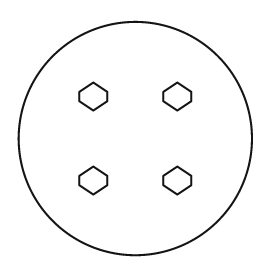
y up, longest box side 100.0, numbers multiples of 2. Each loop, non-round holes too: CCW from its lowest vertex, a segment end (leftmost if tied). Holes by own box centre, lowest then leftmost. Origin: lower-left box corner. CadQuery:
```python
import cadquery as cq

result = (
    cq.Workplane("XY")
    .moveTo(50.0, 50.0)
    .circle(50.0)
    .moveTo(32.0, 26.0)
    .lineTo(38.0, 30.0)
    .lineTo(38.0, 34.0)
    .lineTo(32.0, 38.0)
    .lineTo(26.0, 34.0)
    .lineTo(26.0, 30.0)
    .close()
    .moveTo(68.0, 26.0)
    .lineTo(74.0, 30.0)
    .lineTo(74.0, 34.0)
    .lineTo(68.0, 38.0)
    .lineTo(62.0, 34.0)
    .lineTo(62.0, 30.0)
    .close()
    .moveTo(32.0, 62.0)
    .lineTo(38.0, 66.0)
    .lineTo(38.0, 70.0)
    .lineTo(32.0, 74.0)
    .lineTo(26.0, 70.0)
    .lineTo(26.0, 66.0)
    .close()
    .moveTo(68.0, 62.0)
    .lineTo(74.0, 66.0)
    .lineTo(74.0, 70.0)
    .lineTo(68.0, 74.0)
    .lineTo(62.0, 70.0)
    .lineTo(62.0, 66.0)
    .close()
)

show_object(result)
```